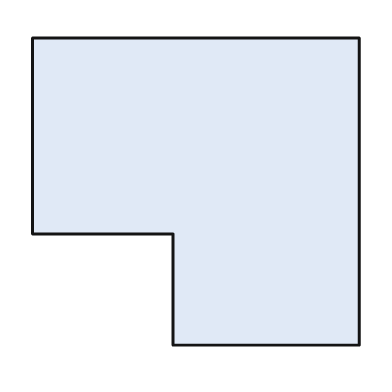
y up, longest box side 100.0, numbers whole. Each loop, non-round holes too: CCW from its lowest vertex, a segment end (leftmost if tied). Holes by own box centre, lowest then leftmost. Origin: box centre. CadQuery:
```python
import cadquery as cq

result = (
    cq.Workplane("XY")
    .moveTo(-7.0, -47.0)
    .lineTo(50.0, -47.0)
    .lineTo(50.0, 47.0)
    .lineTo(-50.0, 47.0)
    .lineTo(-50.0, -13.0)
    .lineTo(-7.0, -13.0)
    .close()
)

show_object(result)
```